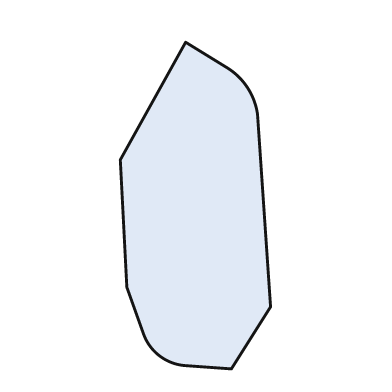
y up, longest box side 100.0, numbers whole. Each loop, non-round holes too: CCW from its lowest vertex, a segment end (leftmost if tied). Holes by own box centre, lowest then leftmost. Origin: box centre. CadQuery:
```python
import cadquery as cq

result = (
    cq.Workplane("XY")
    .moveTo(11.0, -50.0)
    .lineTo(23.0, -31.0)
    .lineTo(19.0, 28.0)
    .threePointArc((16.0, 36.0), (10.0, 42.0))
    .lineTo(-3.0, 50.0)
    .lineTo(-23.0, 14.0)
    .lineTo(-21.0, -25.0)
    .lineTo(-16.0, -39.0)
    .threePointArc((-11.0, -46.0), (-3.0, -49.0))
    .close()
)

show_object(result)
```